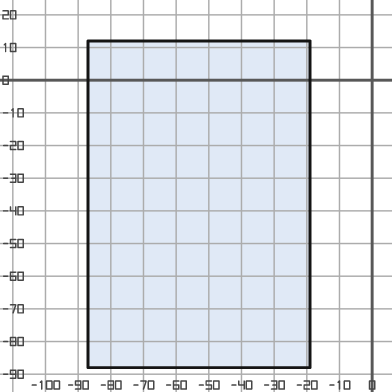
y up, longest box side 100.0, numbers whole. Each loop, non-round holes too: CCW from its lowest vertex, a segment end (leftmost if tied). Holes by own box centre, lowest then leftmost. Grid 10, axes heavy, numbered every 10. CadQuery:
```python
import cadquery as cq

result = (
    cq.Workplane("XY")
    .moveTo(-87.0, -88.0)
    .lineTo(-19.0, -88.0)
    .lineTo(-19.0, 12.0)
    .lineTo(-87.0, 12.0)
    .close()
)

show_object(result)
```